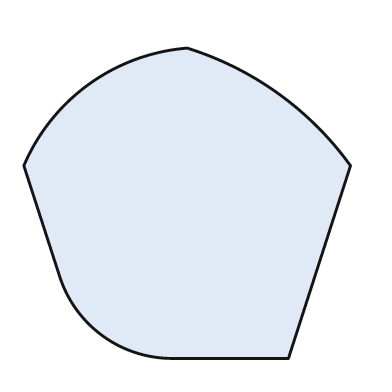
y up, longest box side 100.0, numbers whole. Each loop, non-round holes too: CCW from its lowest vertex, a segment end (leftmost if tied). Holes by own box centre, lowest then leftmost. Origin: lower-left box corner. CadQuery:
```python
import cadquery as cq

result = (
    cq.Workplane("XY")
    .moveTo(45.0, 0.0)
    .lineTo(81.0, 0.0)
    .lineTo(100.0, 59.0)
    .threePointArc((78.0, 81.0), (50.0, 95.0))
    .threePointArc((20.0, 84.0), (0.0, 59.0))
    .lineTo(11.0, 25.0)
    .threePointArc((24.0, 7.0), (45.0, 0.0))
    .close()
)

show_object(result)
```